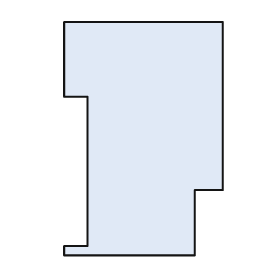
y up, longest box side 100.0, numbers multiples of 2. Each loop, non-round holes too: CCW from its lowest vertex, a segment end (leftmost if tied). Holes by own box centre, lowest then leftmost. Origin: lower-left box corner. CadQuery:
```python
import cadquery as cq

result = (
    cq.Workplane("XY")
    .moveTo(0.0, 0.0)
    .lineTo(56.0, 0.0)
    .lineTo(56.0, 28.0)
    .lineTo(68.0, 28.0)
    .lineTo(68.0, 100.0)
    .lineTo(0.0, 100.0)
    .lineTo(0.0, 68.0)
    .lineTo(10.0, 68.0)
    .lineTo(10.0, 4.0)
    .lineTo(0.0, 4.0)
    .close()
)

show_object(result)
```